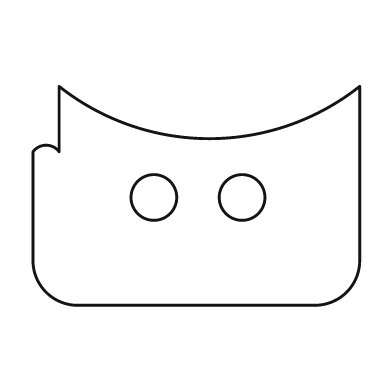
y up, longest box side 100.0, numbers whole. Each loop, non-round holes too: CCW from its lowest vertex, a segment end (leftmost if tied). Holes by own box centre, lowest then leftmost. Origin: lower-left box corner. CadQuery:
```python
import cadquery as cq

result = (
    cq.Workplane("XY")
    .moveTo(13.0, 0.0)
    .lineTo(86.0, 0.0)
    .threePointArc((96.0, 4.0), (100.0, 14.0))
    .lineTo(100.0, 67.0)
    .threePointArc((54.0, 51.0), (8.0, 67.0))
    .lineTo(8.0, 47.0)
    .threePointArc((4.0, 49.0), (0.0, 47.0))
    .lineTo(0.0, 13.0)
    .threePointArc((4.0, 4.0), (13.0, 0.0))
    .close()
    .moveTo(37.0, 33.0)
    .circle(7.0)
    .moveTo(64.0, 33.0)
    .circle(7.0)
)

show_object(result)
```